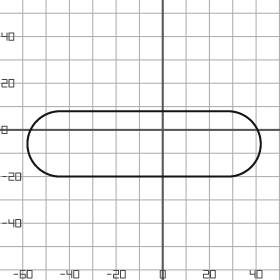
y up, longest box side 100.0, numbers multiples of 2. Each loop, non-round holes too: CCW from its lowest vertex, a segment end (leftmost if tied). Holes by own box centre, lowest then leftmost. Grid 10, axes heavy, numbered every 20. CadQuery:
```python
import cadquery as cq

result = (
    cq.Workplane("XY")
    .moveTo(-44.0, -20.0)
    .lineTo(28.0, -20.0)
    .threePointArc((42.0, -6.0), (28.0, 8.0))
    .lineTo(-44.0, 8.0)
    .threePointArc((-58.0, -6.0), (-44.0, -20.0))
    .close()
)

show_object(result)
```